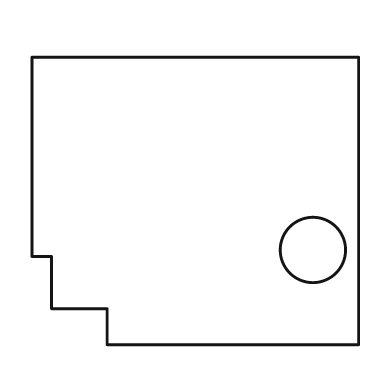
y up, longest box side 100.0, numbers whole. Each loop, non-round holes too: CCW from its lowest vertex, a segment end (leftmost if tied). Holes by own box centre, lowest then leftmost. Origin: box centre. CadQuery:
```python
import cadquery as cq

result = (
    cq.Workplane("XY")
    .moveTo(-27.0, -44.0)
    .lineTo(50.0, -44.0)
    .lineTo(50.0, 44.0)
    .lineTo(-50.0, 44.0)
    .lineTo(-50.0, -17.0)
    .lineTo(-44.0, -17.0)
    .lineTo(-44.0, -33.0)
    .lineTo(-27.0, -33.0)
    .close()
    .moveTo(36.0, -15.0)
    .circle(10.0)
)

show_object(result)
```